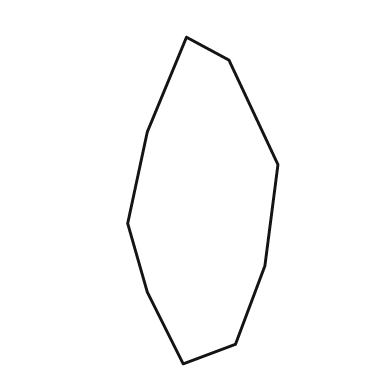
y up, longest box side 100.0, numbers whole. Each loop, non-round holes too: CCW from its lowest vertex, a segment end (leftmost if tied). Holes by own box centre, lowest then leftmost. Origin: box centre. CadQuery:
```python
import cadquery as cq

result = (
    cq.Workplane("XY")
    .moveTo(-6.0, -50.0)
    .lineTo(10.0, -44.0)
    .lineTo(19.0, -20.0)
    .lineTo(23.0, 11.0)
    .lineTo(8.0, 43.0)
    .lineTo(-5.0, 50.0)
    .lineTo(-17.0, 21.0)
    .lineTo(-23.0, -7.0)
    .lineTo(-17.0, -28.0)
    .close()
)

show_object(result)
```